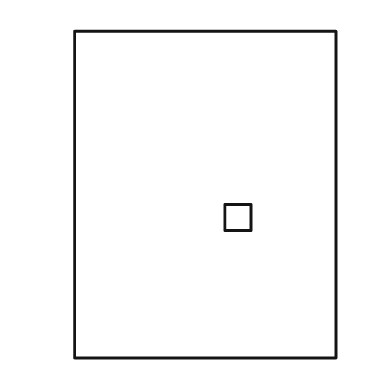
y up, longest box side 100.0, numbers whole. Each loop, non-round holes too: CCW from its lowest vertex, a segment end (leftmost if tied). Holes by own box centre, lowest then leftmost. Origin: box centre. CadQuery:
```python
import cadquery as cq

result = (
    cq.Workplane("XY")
    .moveTo(-40.0, -50.0)
    .lineTo(40.0, -50.0)
    .lineTo(40.0, 50.0)
    .lineTo(-40.0, 50.0)
    .close()
    .moveTo(6.0, -11.0)
    .lineTo(14.0, -11.0)
    .lineTo(14.0, -3.0)
    .lineTo(6.0, -3.0)
    .close()
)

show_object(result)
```